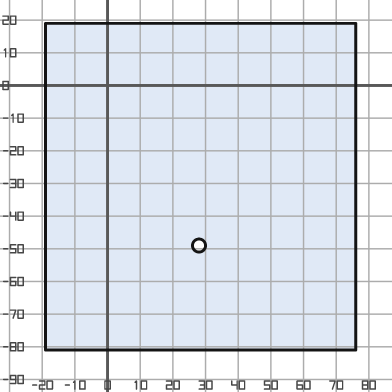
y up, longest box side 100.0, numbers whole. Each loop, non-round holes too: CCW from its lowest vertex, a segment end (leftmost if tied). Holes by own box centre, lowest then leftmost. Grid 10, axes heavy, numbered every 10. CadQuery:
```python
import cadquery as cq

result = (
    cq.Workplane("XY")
    .moveTo(-19.0, -81.0)
    .lineTo(76.0, -81.0)
    .lineTo(76.0, 19.0)
    .lineTo(-19.0, 19.0)
    .close()
    .moveTo(28.0, -49.0)
    .circle(2.0)
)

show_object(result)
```